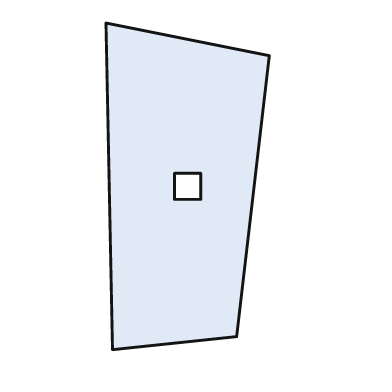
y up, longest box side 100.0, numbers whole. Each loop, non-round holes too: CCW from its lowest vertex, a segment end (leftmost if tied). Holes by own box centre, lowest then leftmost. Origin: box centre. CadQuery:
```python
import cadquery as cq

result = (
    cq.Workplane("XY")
    .moveTo(-23.0, -50.0)
    .lineTo(15.0, -46.0)
    .lineTo(25.0, 40.0)
    .lineTo(-25.0, 50.0)
    .close()
    .moveTo(-4.0, -4.0)
    .lineTo(4.0, -4.0)
    .lineTo(4.0, 4.0)
    .lineTo(-4.0, 4.0)
    .close()
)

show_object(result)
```